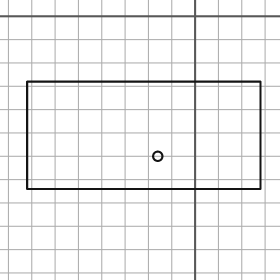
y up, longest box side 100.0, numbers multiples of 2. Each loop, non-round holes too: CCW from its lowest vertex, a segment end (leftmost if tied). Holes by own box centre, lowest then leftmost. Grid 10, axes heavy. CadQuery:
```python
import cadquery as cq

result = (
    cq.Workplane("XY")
    .moveTo(-72.0, -74.0)
    .lineTo(28.0, -74.0)
    .lineTo(28.0, -28.0)
    .lineTo(-72.0, -28.0)
    .close()
    .moveTo(-16.0, -60.0)
    .circle(2.0)
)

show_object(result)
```